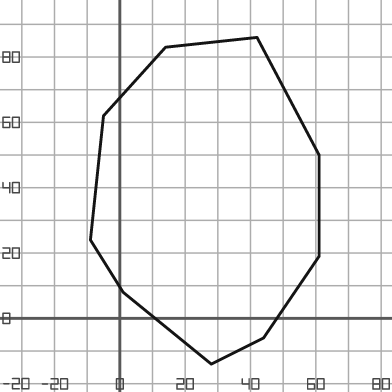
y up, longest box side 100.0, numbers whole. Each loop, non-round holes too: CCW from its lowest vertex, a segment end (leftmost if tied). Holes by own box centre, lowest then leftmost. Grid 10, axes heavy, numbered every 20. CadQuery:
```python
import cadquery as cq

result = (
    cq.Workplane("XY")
    .moveTo(28.0, -14.0)
    .lineTo(44.0, -6.0)
    .lineTo(61.0, 19.0)
    .lineTo(61.0, 50.0)
    .lineTo(42.0, 86.0)
    .lineTo(14.0, 83.0)
    .lineTo(-5.0, 62.0)
    .lineTo(-9.0, 24.0)
    .lineTo(1.0, 8.0)
    .close()
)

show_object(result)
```